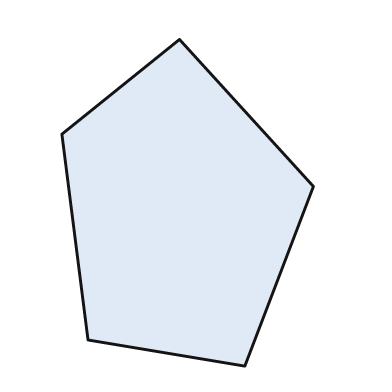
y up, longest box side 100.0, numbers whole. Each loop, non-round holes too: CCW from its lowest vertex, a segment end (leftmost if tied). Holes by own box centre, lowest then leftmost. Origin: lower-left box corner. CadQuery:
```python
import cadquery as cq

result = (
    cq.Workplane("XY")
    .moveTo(56.0, 0.0)
    .lineTo(77.0, 55.0)
    .lineTo(36.0, 100.0)
    .lineTo(0.0, 71.0)
    .lineTo(8.0, 8.0)
    .close()
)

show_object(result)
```